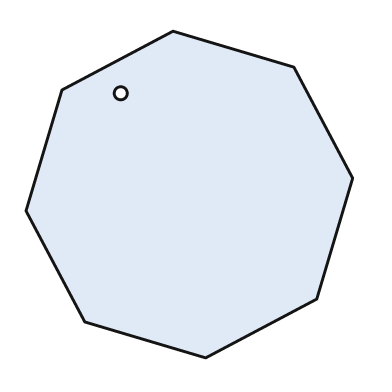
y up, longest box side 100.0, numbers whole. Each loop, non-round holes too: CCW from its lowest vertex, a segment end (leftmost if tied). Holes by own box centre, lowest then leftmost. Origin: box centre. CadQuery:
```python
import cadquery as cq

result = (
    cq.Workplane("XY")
    .moveTo(5.0, -50.0)
    .lineTo(39.0, -32.0)
    .lineTo(50.0, 5.0)
    .lineTo(32.0, 39.0)
    .lineTo(-5.0, 50.0)
    .lineTo(-39.0, 32.0)
    .lineTo(-50.0, -5.0)
    .lineTo(-32.0, -39.0)
    .close()
    .moveTo(-21.0, 31.0)
    .circle(2.0)
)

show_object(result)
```